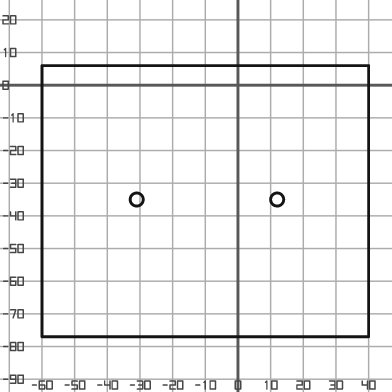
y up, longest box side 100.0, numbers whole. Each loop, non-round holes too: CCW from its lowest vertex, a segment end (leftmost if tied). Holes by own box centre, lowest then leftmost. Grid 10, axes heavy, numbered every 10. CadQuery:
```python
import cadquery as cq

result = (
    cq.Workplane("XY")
    .moveTo(-60.0, -77.0)
    .lineTo(40.0, -77.0)
    .lineTo(40.0, 6.0)
    .lineTo(-60.0, 6.0)
    .close()
    .moveTo(-31.0, -35.0)
    .circle(2.0)
    .moveTo(12.0, -35.0)
    .circle(2.0)
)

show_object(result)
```